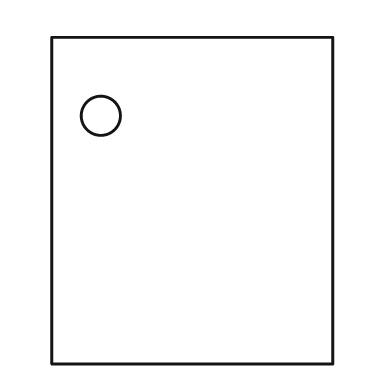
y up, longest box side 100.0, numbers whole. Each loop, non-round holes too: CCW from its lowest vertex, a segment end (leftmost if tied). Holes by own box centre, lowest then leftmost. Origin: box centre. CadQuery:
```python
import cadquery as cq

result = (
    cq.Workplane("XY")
    .moveTo(-43.0, -50.0)
    .lineTo(43.0, -50.0)
    .lineTo(43.0, 50.0)
    .lineTo(-43.0, 50.0)
    .close()
    .moveTo(-28.0, 26.0)
    .circle(6.0)
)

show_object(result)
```